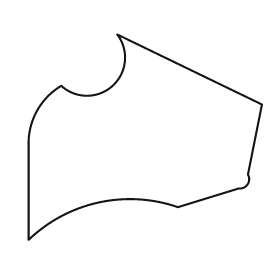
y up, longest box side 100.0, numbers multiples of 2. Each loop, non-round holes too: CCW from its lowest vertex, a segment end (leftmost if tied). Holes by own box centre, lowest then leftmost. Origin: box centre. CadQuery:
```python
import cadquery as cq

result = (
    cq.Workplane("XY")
    .moveTo(-50.0, -44.0)
    .threePointArc((-20.0, -28.0), (14.0, -30.0))
    .lineTo(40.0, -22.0)
    .threePointArc((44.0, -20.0), (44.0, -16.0))
    .lineTo(50.0, 14.0)
    .lineTo(-12.0, 44.0)
    .threePointArc((-14.0, 22.0), (-36.0, 22.0))
    .threePointArc((-46.0, 12.0), (-50.0, -2.0))
    .close()
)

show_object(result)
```